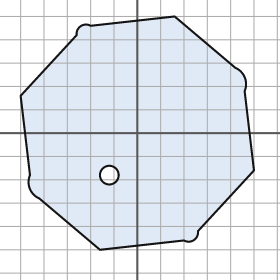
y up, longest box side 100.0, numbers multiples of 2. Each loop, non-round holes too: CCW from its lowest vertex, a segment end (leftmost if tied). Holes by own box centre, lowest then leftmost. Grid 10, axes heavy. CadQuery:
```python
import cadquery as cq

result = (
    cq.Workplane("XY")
    .moveTo(-16.0, -50.0)
    .lineTo(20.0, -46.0)
    .threePointArc((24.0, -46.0), (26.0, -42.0))
    .lineTo(50.0, -16.0)
    .lineTo(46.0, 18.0)
    .threePointArc((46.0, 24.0), (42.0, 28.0))
    .lineTo(16.0, 50.0)
    .lineTo(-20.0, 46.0)
    .threePointArc((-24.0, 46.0), (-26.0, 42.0))
    .lineTo(-50.0, 16.0)
    .lineTo(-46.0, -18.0)
    .threePointArc((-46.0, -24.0), (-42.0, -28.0))
    .close()
    .moveTo(-12.0, -18.0)
    .circle(4.0)
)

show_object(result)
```